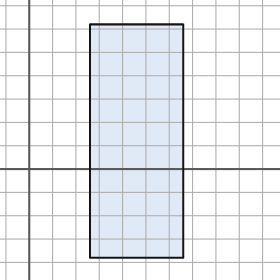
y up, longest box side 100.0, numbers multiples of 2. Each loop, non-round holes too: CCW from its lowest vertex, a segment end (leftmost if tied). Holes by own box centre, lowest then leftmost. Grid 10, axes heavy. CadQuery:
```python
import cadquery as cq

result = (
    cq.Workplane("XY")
    .moveTo(26.0, -38.0)
    .lineTo(66.0, -38.0)
    .lineTo(66.0, 62.0)
    .lineTo(26.0, 62.0)
    .close()
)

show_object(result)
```